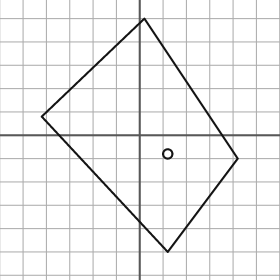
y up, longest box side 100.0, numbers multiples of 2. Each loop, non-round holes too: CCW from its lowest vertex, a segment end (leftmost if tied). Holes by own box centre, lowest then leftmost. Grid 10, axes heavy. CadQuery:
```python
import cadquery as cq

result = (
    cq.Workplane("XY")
    .moveTo(12.0, -50.0)
    .lineTo(42.0, -10.0)
    .lineTo(2.0, 50.0)
    .lineTo(-42.0, 8.0)
    .close()
    .moveTo(12.0, -8.0)
    .circle(2.0)
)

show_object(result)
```